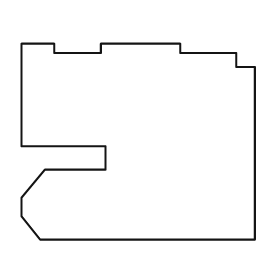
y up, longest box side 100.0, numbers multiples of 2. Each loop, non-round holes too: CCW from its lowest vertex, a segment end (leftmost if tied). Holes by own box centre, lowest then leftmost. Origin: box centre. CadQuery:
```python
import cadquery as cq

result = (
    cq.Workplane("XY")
    .moveTo(-42.0, -42.0)
    .lineTo(50.0, -42.0)
    .lineTo(50.0, 32.0)
    .lineTo(42.0, 32.0)
    .lineTo(42.0, 38.0)
    .lineTo(18.0, 38.0)
    .lineTo(18.0, 42.0)
    .lineTo(-16.0, 42.0)
    .lineTo(-16.0, 38.0)
    .lineTo(-36.0, 38.0)
    .lineTo(-36.0, 42.0)
    .lineTo(-50.0, 42.0)
    .lineTo(-50.0, -2.0)
    .lineTo(-14.0, -2.0)
    .lineTo(-14.0, -12.0)
    .lineTo(-40.0, -12.0)
    .lineTo(-50.0, -24.0)
    .lineTo(-50.0, -32.0)
    .close()
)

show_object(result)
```